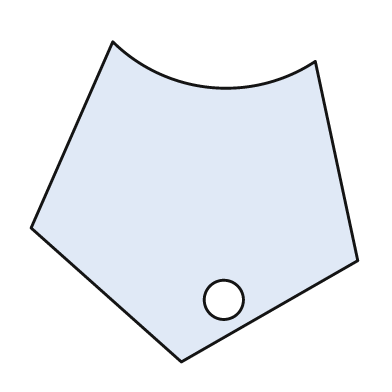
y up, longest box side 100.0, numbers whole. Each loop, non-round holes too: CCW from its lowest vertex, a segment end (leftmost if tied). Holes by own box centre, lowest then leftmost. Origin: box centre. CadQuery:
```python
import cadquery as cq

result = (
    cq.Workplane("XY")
    .moveTo(-4.0, -49.0)
    .lineTo(50.0, -18.0)
    .lineTo(37.0, 43.0)
    .threePointArc((5.0, 35.0), (-25.0, 49.0))
    .lineTo(-50.0, -8.0)
    .close()
    .moveTo(9.0, -30.0)
    .circle(6.0)
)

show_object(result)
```